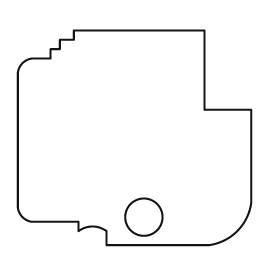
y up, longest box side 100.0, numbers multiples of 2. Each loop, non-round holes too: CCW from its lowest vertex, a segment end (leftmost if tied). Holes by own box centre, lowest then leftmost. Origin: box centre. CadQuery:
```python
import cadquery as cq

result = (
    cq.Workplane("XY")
    .moveTo(-12.0, -46.0)
    .lineTo(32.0, -46.0)
    .threePointArc((44.0, -40.0), (50.0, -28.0))
    .lineTo(50.0, 12.0)
    .lineTo(30.0, 12.0)
    .lineTo(30.0, 46.0)
    .lineTo(-26.0, 46.0)
    .lineTo(-26.0, 42.0)
    .lineTo(-32.0, 42.0)
    .lineTo(-32.0, 38.0)
    .lineTo(-36.0, 38.0)
    .lineTo(-36.0, 34.0)
    .lineTo(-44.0, 34.0)
    .threePointArc((-48.0, 32.0), (-50.0, 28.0))
    .lineTo(-50.0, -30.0)
    .threePointArc((-48.0, -34.0), (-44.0, -36.0))
    .lineTo(-24.0, -36.0)
    .lineTo(-24.0, -40.0)
    .threePointArc((-18.0, -38.0), (-12.0, -40.0))
    .close()
    .moveTo(4.0, -34.0)
    .circle(8.0)
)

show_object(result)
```